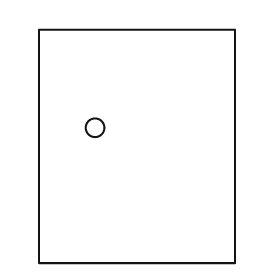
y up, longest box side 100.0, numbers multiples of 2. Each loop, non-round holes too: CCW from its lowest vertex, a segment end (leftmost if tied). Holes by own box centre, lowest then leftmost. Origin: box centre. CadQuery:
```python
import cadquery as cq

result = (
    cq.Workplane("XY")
    .moveTo(-42.0, -50.0)
    .lineTo(42.0, -50.0)
    .lineTo(42.0, 50.0)
    .lineTo(-42.0, 50.0)
    .close()
    .moveTo(-18.0, 8.0)
    .circle(4.0)
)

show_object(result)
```